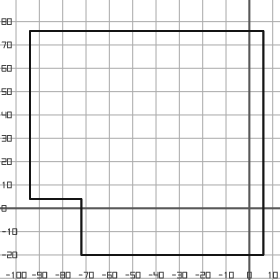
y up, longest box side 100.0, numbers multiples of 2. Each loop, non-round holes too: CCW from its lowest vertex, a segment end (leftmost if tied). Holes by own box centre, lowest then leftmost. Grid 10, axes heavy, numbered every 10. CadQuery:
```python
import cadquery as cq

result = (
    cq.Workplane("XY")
    .moveTo(-72.0, -20.0)
    .lineTo(6.0, -20.0)
    .lineTo(6.0, 76.0)
    .lineTo(-94.0, 76.0)
    .lineTo(-94.0, 4.0)
    .lineTo(-72.0, 4.0)
    .close()
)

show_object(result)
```